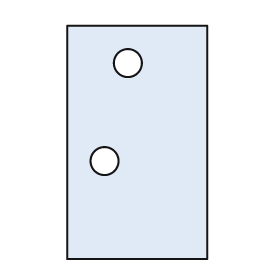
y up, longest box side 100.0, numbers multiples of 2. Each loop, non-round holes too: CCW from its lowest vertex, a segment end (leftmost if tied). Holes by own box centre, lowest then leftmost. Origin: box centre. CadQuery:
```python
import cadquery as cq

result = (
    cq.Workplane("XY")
    .moveTo(-30.0, -50.0)
    .lineTo(30.0, -50.0)
    .lineTo(30.0, 50.0)
    .lineTo(-30.0, 50.0)
    .close()
    .moveTo(-14.0, -8.0)
    .circle(6.0)
    .moveTo(-4.0, 34.0)
    .circle(6.0)
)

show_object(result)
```